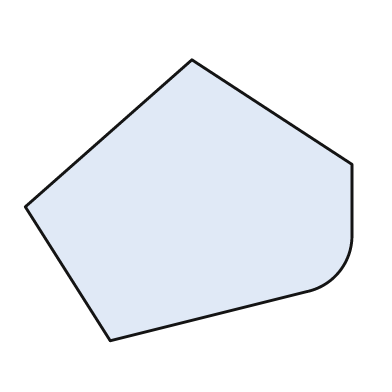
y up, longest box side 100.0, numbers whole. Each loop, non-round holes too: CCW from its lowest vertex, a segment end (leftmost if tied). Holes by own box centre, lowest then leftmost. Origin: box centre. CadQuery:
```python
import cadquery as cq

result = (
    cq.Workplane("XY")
    .moveTo(-24.0, -43.0)
    .lineTo(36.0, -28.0)
    .threePointArc((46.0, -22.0), (50.0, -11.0))
    .lineTo(50.0, 11.0)
    .lineTo(1.0, 43.0)
    .lineTo(-50.0, -2.0)
    .close()
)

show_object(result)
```